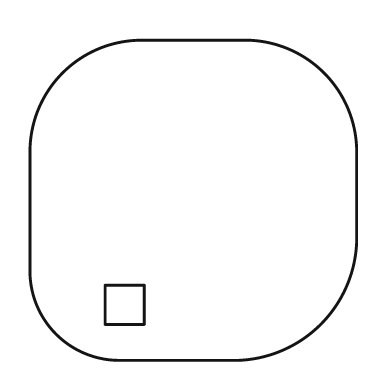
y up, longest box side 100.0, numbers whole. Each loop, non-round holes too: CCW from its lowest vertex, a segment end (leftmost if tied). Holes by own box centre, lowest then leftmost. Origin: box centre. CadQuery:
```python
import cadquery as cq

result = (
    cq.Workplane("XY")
    .moveTo(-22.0, -49.0)
    .lineTo(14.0, -49.0)
    .threePointArc((39.0, -38.0), (50.0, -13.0))
    .lineTo(50.0, 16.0)
    .threePointArc((40.0, 39.0), (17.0, 49.0))
    .lineTo(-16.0, 49.0)
    .threePointArc((-40.0, 39.0), (-50.0, 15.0))
    .lineTo(-50.0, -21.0)
    .threePointArc((-42.0, -41.0), (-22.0, -49.0))
    .close()
    .moveTo(-27.0, -38.0)
    .lineTo(-15.0, -38.0)
    .lineTo(-15.0, -26.0)
    .lineTo(-27.0, -26.0)
    .close()
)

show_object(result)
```